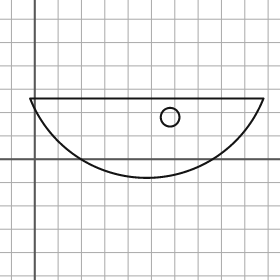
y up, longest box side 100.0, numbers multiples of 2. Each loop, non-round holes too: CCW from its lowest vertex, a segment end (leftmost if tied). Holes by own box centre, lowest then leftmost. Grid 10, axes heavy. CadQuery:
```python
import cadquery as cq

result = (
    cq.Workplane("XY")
    .moveTo(-2.0, 26.0)
    .threePointArc((48.0, -8.0), (98.0, 26.0))
    .close()
    .moveTo(58.0, 18.0)
    .circle(4.0)
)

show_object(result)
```